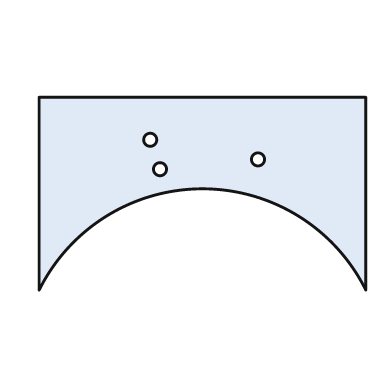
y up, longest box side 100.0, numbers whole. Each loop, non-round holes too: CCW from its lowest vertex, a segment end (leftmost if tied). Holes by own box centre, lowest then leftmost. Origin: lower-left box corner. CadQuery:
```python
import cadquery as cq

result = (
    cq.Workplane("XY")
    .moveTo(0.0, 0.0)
    .threePointArc((50.0, 31.0), (100.0, 0.0))
    .lineTo(100.0, 59.0)
    .lineTo(0.0, 59.0)
    .close()
    .moveTo(37.0, 37.0)
    .circle(2.0)
    .moveTo(67.0, 40.0)
    .circle(2.0)
    .moveTo(34.0, 46.0)
    .circle(2.0)
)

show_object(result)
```